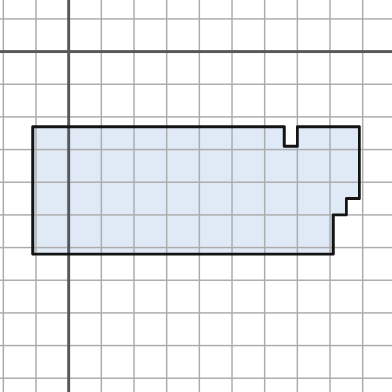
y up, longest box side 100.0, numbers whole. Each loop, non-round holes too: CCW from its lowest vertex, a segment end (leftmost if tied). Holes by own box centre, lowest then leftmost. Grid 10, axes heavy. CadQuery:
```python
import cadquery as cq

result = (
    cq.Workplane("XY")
    .moveTo(-11.0, -62.0)
    .lineTo(81.0, -62.0)
    .lineTo(81.0, -50.0)
    .lineTo(85.0, -50.0)
    .lineTo(85.0, -45.0)
    .lineTo(89.0, -45.0)
    .lineTo(89.0, -23.0)
    .lineTo(70.0, -23.0)
    .lineTo(70.0, -29.0)
    .lineTo(66.0, -29.0)
    .lineTo(66.0, -23.0)
    .lineTo(-11.0, -23.0)
    .close()
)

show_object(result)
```